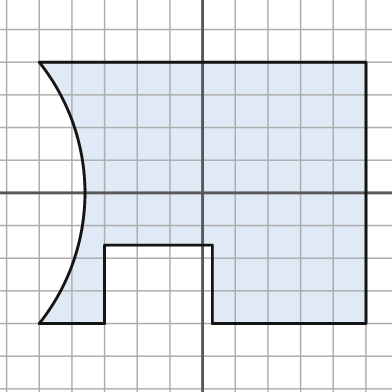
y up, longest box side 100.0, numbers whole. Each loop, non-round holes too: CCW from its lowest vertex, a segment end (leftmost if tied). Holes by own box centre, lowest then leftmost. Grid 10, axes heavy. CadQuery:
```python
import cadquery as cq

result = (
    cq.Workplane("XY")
    .moveTo(-50.0, -40.0)
    .lineTo(-30.0, -40.0)
    .lineTo(-30.0, -16.0)
    .lineTo(3.0, -16.0)
    .lineTo(3.0, -40.0)
    .lineTo(50.0, -40.0)
    .lineTo(50.0, 40.0)
    .lineTo(-50.0, 40.0)
    .threePointArc((-36.0, 0.0), (-50.0, -40.0))
    .close()
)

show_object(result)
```